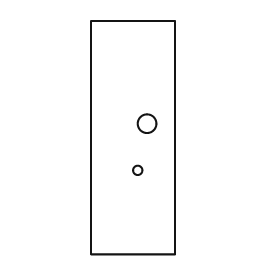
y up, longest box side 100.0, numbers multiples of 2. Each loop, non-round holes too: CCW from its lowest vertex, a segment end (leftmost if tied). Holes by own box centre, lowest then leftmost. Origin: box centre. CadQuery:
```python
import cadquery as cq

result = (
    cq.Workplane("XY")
    .moveTo(-18.0, -50.0)
    .lineTo(18.0, -50.0)
    .lineTo(18.0, 50.0)
    .lineTo(-18.0, 50.0)
    .close()
    .moveTo(2.0, -14.0)
    .circle(2.0)
    .moveTo(6.0, 6.0)
    .circle(4.0)
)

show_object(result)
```